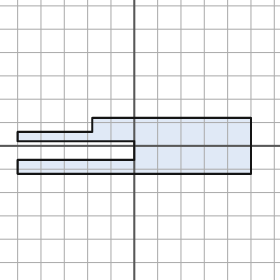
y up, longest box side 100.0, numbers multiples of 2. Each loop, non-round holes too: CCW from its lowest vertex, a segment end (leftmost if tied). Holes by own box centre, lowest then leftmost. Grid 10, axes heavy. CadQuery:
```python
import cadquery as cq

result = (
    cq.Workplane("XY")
    .moveTo(-50.0, -12.0)
    .lineTo(50.0, -12.0)
    .lineTo(50.0, 12.0)
    .lineTo(-18.0, 12.0)
    .lineTo(-18.0, 6.0)
    .lineTo(-50.0, 6.0)
    .lineTo(-50.0, 2.0)
    .lineTo(0.0, 2.0)
    .lineTo(0.0, -6.0)
    .lineTo(-50.0, -6.0)
    .close()
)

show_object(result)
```